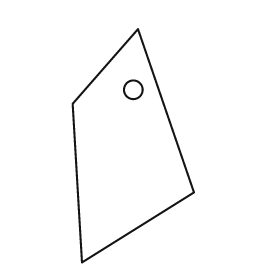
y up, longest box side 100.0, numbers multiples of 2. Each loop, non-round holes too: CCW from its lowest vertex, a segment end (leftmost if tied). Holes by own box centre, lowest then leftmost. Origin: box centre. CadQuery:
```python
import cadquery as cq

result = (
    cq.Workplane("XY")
    .moveTo(-22.0, -50.0)
    .lineTo(26.0, -20.0)
    .lineTo(2.0, 50.0)
    .lineTo(-26.0, 18.0)
    .close()
    .moveTo(0.0, 24.0)
    .circle(4.0)
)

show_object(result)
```